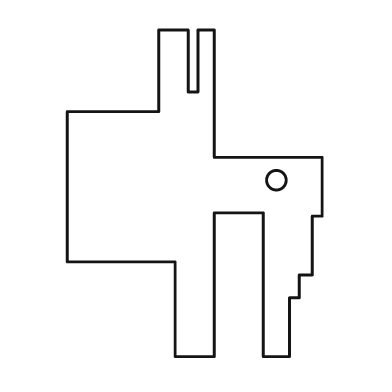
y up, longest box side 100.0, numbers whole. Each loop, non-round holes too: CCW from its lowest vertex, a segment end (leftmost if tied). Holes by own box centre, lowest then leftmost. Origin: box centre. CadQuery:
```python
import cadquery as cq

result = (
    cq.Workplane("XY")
    .moveTo(-6.0, -50.0)
    .lineTo(6.0, -50.0)
    .lineTo(6.0, -6.0)
    .lineTo(21.0, -6.0)
    .lineTo(21.0, -50.0)
    .lineTo(29.0, -50.0)
    .lineTo(29.0, -32.0)
    .lineTo(32.0, -32.0)
    .lineTo(32.0, -25.0)
    .lineTo(36.0, -25.0)
    .lineTo(36.0, -7.0)
    .lineTo(39.0, -7.0)
    .lineTo(39.0, 11.0)
    .lineTo(6.0, 11.0)
    .lineTo(6.0, 50.0)
    .lineTo(1.0, 50.0)
    .lineTo(1.0, 31.0)
    .lineTo(-2.0, 31.0)
    .lineTo(-2.0, 50.0)
    .lineTo(-11.0, 50.0)
    .lineTo(-11.0, 25.0)
    .lineTo(-39.0, 25.0)
    .lineTo(-39.0, -21.0)
    .lineTo(-6.0, -21.0)
    .close()
    .moveTo(25.0, 4.0)
    .circle(3.0)
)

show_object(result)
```